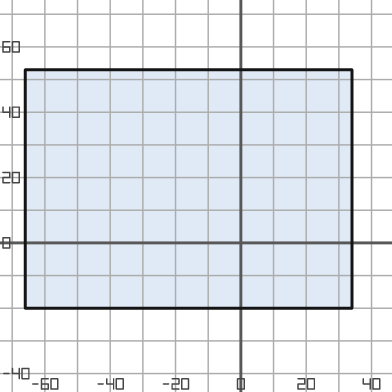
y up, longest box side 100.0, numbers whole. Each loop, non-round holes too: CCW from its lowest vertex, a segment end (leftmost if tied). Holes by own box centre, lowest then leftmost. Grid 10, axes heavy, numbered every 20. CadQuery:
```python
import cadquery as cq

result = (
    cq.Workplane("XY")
    .moveTo(-66.0, -20.0)
    .lineTo(34.0, -20.0)
    .lineTo(34.0, 53.0)
    .lineTo(-66.0, 53.0)
    .close()
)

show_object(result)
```